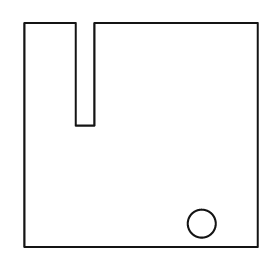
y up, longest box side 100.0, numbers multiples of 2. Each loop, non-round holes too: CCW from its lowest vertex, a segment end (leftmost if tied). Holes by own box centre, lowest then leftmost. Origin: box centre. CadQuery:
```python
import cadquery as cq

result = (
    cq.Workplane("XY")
    .moveTo(-50.0, -48.0)
    .lineTo(50.0, -48.0)
    .lineTo(50.0, 48.0)
    .lineTo(-20.0, 48.0)
    .lineTo(-20.0, 4.0)
    .lineTo(-28.0, 4.0)
    .lineTo(-28.0, 48.0)
    .lineTo(-50.0, 48.0)
    .close()
    .moveTo(26.0, -38.0)
    .circle(6.0)
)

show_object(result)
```